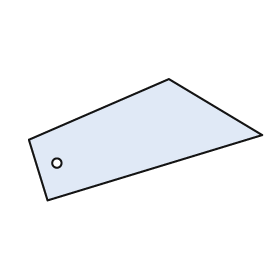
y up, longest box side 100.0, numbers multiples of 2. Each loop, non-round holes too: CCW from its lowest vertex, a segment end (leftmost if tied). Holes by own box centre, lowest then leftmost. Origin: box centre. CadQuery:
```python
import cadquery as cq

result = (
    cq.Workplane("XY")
    .moveTo(-42.0, -26.0)
    .lineTo(50.0, 2.0)
    .lineTo(10.0, 26.0)
    .lineTo(-50.0, 0.0)
    .close()
    .moveTo(-38.0, -10.0)
    .circle(2.0)
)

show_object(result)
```